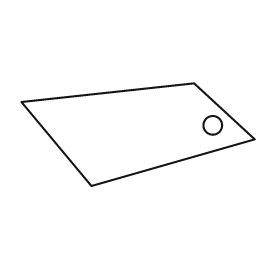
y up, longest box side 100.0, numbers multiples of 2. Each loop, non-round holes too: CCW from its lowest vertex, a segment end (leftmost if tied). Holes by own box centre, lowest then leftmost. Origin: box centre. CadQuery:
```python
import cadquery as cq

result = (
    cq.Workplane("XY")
    .moveTo(-20.0, -22.0)
    .lineTo(50.0, -2.0)
    .lineTo(24.0, 22.0)
    .lineTo(-50.0, 14.0)
    .close()
    .moveTo(32.0, 4.0)
    .circle(4.0)
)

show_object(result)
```